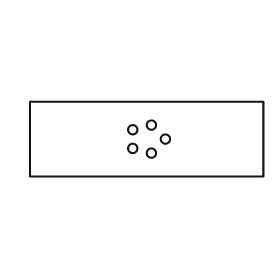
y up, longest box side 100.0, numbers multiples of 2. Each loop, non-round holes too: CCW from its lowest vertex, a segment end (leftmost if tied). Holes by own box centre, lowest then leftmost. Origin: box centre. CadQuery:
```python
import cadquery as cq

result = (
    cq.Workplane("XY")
    .moveTo(-50.0, -16.0)
    .lineTo(50.0, -16.0)
    .lineTo(50.0, 16.0)
    .lineTo(-50.0, 16.0)
    .close()
    .moveTo(2.0, -6.0)
    .circle(2.0)
    .moveTo(-6.0, -4.0)
    .circle(2.0)
    .moveTo(8.0, 0.0)
    .circle(2.0)
    .moveTo(-6.0, 4.0)
    .circle(2.0)
    .moveTo(2.0, 6.0)
    .circle(2.0)
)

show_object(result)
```